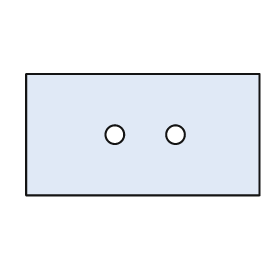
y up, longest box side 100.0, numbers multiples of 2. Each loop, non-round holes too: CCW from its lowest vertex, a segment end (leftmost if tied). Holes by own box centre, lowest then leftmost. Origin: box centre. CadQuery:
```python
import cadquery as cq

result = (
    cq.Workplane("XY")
    .moveTo(-50.0, -26.0)
    .lineTo(50.0, -26.0)
    .lineTo(50.0, 26.0)
    .lineTo(-50.0, 26.0)
    .close()
    .moveTo(-12.0, 0.0)
    .circle(4.0)
    .moveTo(14.0, 0.0)
    .circle(4.0)
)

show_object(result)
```